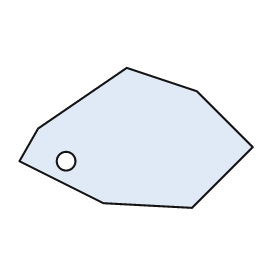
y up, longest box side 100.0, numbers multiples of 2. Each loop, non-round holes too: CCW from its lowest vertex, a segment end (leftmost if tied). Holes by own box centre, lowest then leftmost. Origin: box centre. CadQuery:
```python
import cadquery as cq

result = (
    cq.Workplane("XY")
    .moveTo(24.0, -30.0)
    .lineTo(50.0, -4.0)
    .lineTo(26.0, 20.0)
    .lineTo(-4.0, 30.0)
    .lineTo(-42.0, 4.0)
    .lineTo(-50.0, -10.0)
    .lineTo(-14.0, -28.0)
    .close()
    .moveTo(-30.0, -10.0)
    .circle(4.0)
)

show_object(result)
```